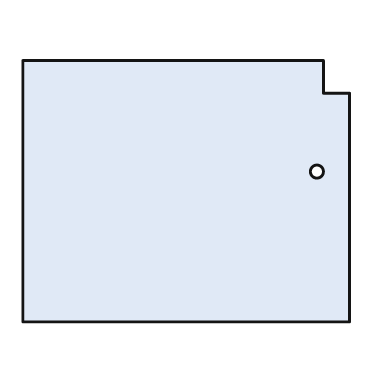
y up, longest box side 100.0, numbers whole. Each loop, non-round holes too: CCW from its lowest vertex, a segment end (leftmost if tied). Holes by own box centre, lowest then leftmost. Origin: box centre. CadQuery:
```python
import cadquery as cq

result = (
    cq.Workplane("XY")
    .moveTo(-50.0, -40.0)
    .lineTo(50.0, -40.0)
    .lineTo(50.0, 30.0)
    .lineTo(42.0, 30.0)
    .lineTo(42.0, 40.0)
    .lineTo(-50.0, 40.0)
    .close()
    .moveTo(40.0, 6.0)
    .circle(2.0)
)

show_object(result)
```